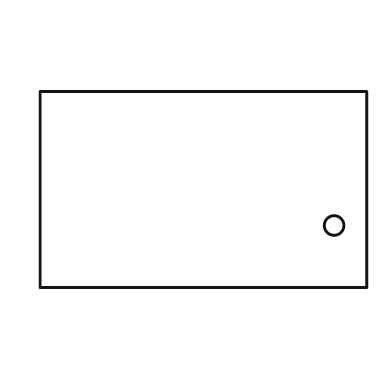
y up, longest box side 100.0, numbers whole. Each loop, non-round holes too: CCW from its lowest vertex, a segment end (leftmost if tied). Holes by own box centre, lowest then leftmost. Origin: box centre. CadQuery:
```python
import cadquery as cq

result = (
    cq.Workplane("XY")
    .moveTo(-50.0, -30.0)
    .lineTo(50.0, -30.0)
    .lineTo(50.0, 30.0)
    .lineTo(-50.0, 30.0)
    .close()
    .moveTo(40.0, -11.0)
    .circle(3.0)
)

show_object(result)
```